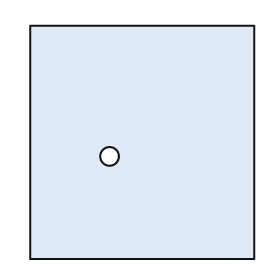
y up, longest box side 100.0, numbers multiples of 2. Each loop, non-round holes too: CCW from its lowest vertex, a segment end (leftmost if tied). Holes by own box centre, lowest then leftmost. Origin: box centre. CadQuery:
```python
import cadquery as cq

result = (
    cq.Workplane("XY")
    .moveTo(-48.0, -50.0)
    .lineTo(48.0, -50.0)
    .lineTo(48.0, 50.0)
    .lineTo(-48.0, 50.0)
    .close()
    .moveTo(-14.0, -6.0)
    .circle(4.0)
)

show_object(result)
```